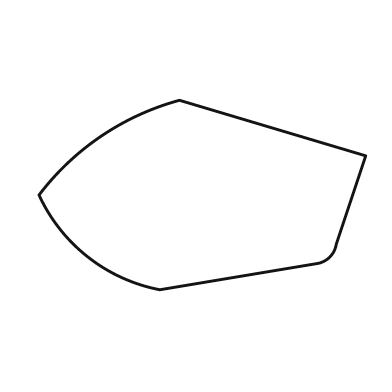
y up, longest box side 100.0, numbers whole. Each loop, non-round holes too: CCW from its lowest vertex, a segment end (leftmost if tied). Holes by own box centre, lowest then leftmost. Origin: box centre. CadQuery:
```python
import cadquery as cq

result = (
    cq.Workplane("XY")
    .moveTo(-13.0, -29.0)
    .lineTo(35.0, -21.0)
    .threePointArc((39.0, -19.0), (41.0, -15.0))
    .lineTo(50.0, 12.0)
    .lineTo(-7.0, 29.0)
    .threePointArc((-31.0, 18.0), (-50.0, 0.0))
    .threePointArc((-35.0, -19.0), (-13.0, -29.0))
    .close()
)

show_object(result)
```